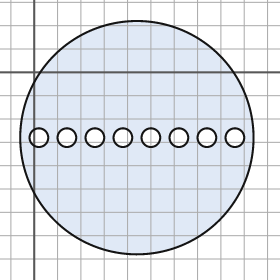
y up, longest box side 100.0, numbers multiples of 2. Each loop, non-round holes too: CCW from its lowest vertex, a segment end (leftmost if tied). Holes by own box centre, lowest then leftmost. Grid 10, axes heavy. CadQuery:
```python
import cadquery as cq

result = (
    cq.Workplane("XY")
    .moveTo(44.0, -28.0)
    .circle(50.0)
    .moveTo(2.0, -28.0)
    .circle(4.0)
    .moveTo(14.0, -28.0)
    .circle(4.0)
    .moveTo(26.0, -28.0)
    .circle(4.0)
    .moveTo(38.0, -28.0)
    .circle(4.0)
    .moveTo(50.0, -28.0)
    .circle(4.0)
    .moveTo(62.0, -28.0)
    .circle(4.0)
    .moveTo(74.0, -28.0)
    .circle(4.0)
    .moveTo(86.0, -28.0)
    .circle(4.0)
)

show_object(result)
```